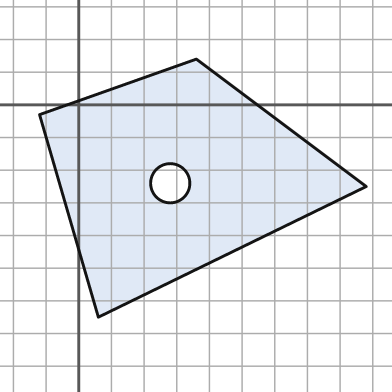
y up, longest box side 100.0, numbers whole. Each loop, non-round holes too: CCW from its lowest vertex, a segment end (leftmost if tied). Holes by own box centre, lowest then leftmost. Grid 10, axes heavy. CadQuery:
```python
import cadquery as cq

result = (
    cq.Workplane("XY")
    .moveTo(6.0, -65.0)
    .lineTo(88.0, -25.0)
    .lineTo(36.0, 14.0)
    .lineTo(-12.0, -3.0)
    .close()
    .moveTo(28.0, -24.0)
    .circle(6.0)
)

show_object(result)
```